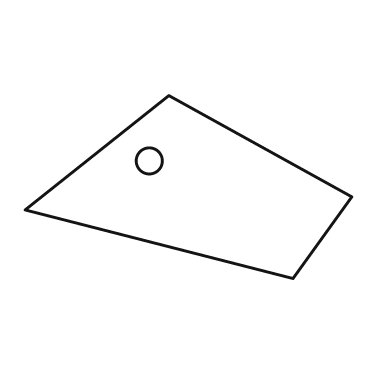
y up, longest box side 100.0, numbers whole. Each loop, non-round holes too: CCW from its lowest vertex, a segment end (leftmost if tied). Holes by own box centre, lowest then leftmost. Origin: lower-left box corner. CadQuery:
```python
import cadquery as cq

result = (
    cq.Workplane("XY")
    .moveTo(82.0, 0.0)
    .lineTo(100.0, 25.0)
    .lineTo(44.0, 56.0)
    .lineTo(0.0, 21.0)
    .close()
    .moveTo(38.0, 36.0)
    .circle(4.0)
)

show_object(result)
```